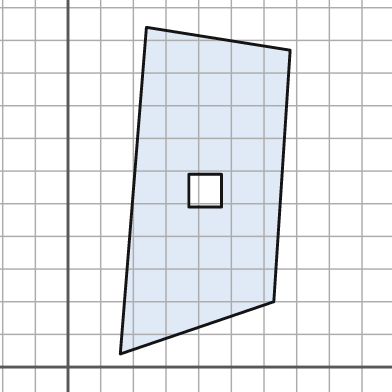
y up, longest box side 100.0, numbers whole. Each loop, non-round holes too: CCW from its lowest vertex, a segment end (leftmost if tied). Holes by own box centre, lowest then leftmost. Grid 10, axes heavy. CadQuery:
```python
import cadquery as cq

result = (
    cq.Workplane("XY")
    .moveTo(16.0, 4.0)
    .lineTo(63.0, 20.0)
    .lineTo(68.0, 97.0)
    .lineTo(24.0, 104.0)
    .close()
    .moveTo(37.0, 49.0)
    .lineTo(47.0, 49.0)
    .lineTo(47.0, 59.0)
    .lineTo(37.0, 59.0)
    .close()
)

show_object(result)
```